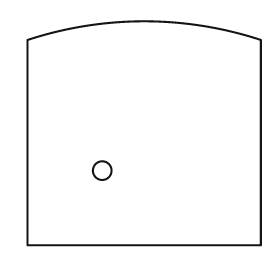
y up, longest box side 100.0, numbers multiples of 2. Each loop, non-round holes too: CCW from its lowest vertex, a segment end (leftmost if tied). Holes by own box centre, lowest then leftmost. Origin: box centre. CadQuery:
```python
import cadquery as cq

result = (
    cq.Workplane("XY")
    .moveTo(-50.0, -48.0)
    .lineTo(50.0, -48.0)
    .lineTo(50.0, 40.0)
    .threePointArc((0.0, 48.0), (-50.0, 40.0))
    .close()
    .moveTo(-18.0, -16.0)
    .circle(4.0)
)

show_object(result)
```